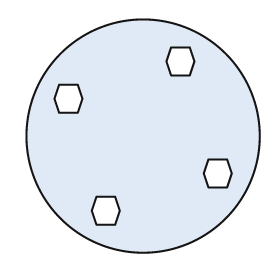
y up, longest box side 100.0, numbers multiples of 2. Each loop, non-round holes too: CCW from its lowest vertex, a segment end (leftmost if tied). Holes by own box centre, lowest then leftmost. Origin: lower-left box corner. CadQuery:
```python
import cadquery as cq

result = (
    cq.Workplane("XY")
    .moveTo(50.0, 50.0)
    .circle(50.0)
    .moveTo(30.0, 12.0)
    .lineTo(38.0, 12.0)
    .lineTo(40.0, 18.0)
    .lineTo(38.0, 24.0)
    .lineTo(30.0, 24.0)
    .lineTo(28.0, 18.0)
    .close()
    .moveTo(78.0, 28.0)
    .lineTo(86.0, 28.0)
    .lineTo(88.0, 34.0)
    .lineTo(86.0, 40.0)
    .lineTo(78.0, 40.0)
    .lineTo(76.0, 34.0)
    .close()
    .moveTo(14.0, 60.0)
    .lineTo(22.0, 60.0)
    .lineTo(24.0, 66.0)
    .lineTo(22.0, 72.0)
    .lineTo(14.0, 72.0)
    .lineTo(12.0, 66.0)
    .close()
    .moveTo(62.0, 76.0)
    .lineTo(70.0, 76.0)
    .lineTo(72.0, 82.0)
    .lineTo(70.0, 88.0)
    .lineTo(62.0, 88.0)
    .lineTo(60.0, 82.0)
    .close()
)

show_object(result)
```